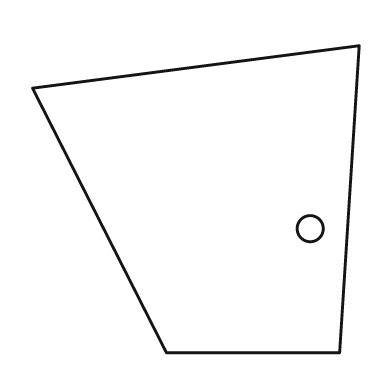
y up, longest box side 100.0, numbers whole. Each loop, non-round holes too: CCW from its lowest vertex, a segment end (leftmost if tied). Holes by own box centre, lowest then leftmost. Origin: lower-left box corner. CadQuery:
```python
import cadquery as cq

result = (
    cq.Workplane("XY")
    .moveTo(41.0, 0.0)
    .lineTo(94.0, 0.0)
    .lineTo(100.0, 94.0)
    .lineTo(0.0, 81.0)
    .close()
    .moveTo(85.0, 38.0)
    .circle(4.0)
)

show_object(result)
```